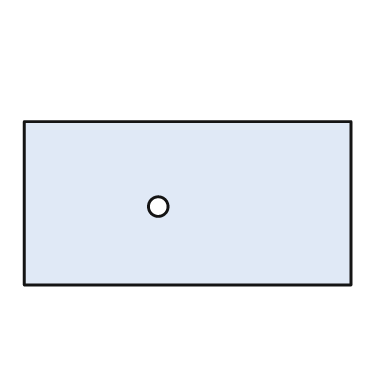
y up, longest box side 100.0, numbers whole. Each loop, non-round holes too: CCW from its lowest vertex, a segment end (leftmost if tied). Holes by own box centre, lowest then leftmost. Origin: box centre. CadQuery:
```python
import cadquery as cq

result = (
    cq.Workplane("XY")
    .moveTo(-50.0, -25.0)
    .lineTo(50.0, -25.0)
    .lineTo(50.0, 25.0)
    .lineTo(-50.0, 25.0)
    .close()
    .moveTo(-9.0, -1.0)
    .circle(3.0)
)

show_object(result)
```